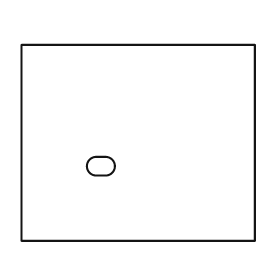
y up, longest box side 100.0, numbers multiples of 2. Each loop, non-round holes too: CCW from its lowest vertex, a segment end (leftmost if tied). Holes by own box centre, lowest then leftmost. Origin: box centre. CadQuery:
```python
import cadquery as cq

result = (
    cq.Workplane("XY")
    .moveTo(-50.0, -42.0)
    .lineTo(50.0, -42.0)
    .lineTo(50.0, 42.0)
    .lineTo(-50.0, 42.0)
    .close()
    .moveTo(-18.0, -14.0)
    .lineTo(-14.0, -14.0)
    .threePointArc((-10.0, -10.0), (-14.0, -6.0))
    .lineTo(-18.0, -6.0)
    .threePointArc((-22.0, -10.0), (-18.0, -14.0))
    .close()
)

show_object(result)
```